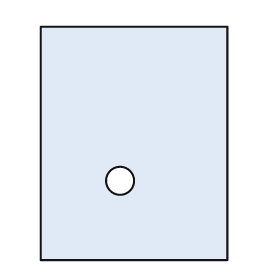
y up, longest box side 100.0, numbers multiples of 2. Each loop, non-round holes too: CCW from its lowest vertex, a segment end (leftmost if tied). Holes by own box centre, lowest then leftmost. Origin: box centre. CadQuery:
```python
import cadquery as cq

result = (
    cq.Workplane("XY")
    .moveTo(-40.0, -50.0)
    .lineTo(40.0, -50.0)
    .lineTo(40.0, 50.0)
    .lineTo(-40.0, 50.0)
    .close()
    .moveTo(-6.0, -16.0)
    .circle(6.0)
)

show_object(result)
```